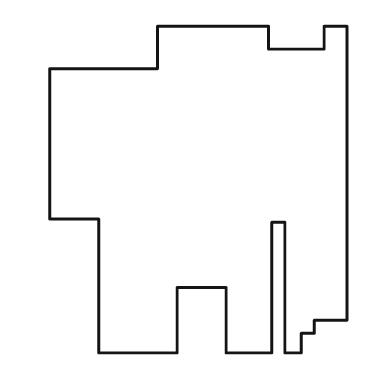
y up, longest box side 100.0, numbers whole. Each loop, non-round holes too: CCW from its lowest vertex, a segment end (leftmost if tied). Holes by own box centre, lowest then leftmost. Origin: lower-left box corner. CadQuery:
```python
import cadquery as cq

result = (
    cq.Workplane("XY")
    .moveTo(15.0, 0.0)
    .lineTo(39.0, 0.0)
    .lineTo(39.0, 20.0)
    .lineTo(54.0, 20.0)
    .lineTo(54.0, 0.0)
    .lineTo(68.0, 0.0)
    .lineTo(68.0, 40.0)
    .lineTo(72.0, 40.0)
    .lineTo(72.0, 0.0)
    .lineTo(77.0, 0.0)
    .lineTo(77.0, 6.0)
    .lineTo(81.0, 6.0)
    .lineTo(81.0, 10.0)
    .lineTo(91.0, 10.0)
    .lineTo(91.0, 100.0)
    .lineTo(84.0, 100.0)
    .lineTo(84.0, 93.0)
    .lineTo(67.0, 93.0)
    .lineTo(67.0, 100.0)
    .lineTo(33.0, 100.0)
    .lineTo(33.0, 87.0)
    .lineTo(0.0, 87.0)
    .lineTo(0.0, 41.0)
    .lineTo(15.0, 41.0)
    .close()
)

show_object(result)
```